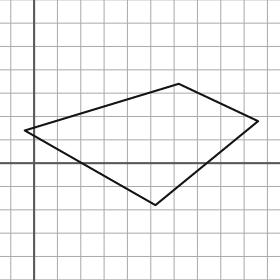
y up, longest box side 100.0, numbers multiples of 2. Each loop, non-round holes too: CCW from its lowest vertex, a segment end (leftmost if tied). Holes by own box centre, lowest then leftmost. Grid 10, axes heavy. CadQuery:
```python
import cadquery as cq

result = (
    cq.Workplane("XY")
    .moveTo(52.0, -18.0)
    .lineTo(96.0, 18.0)
    .lineTo(62.0, 34.0)
    .lineTo(-4.0, 14.0)
    .close()
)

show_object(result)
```